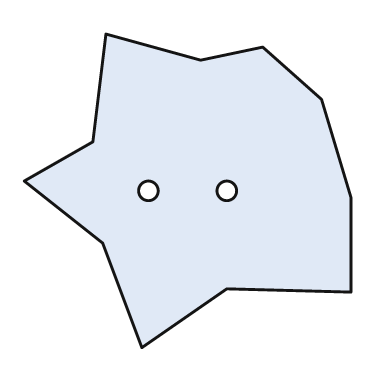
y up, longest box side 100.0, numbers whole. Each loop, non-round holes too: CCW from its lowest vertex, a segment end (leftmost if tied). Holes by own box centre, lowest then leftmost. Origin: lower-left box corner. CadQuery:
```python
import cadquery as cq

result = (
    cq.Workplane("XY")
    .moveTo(36.0, 0.0)
    .lineTo(62.0, 18.0)
    .lineTo(100.0, 17.0)
    .lineTo(100.0, 46.0)
    .lineTo(91.0, 76.0)
    .lineTo(73.0, 92.0)
    .lineTo(54.0, 88.0)
    .lineTo(25.0, 96.0)
    .lineTo(21.0, 63.0)
    .lineTo(0.0, 51.0)
    .lineTo(24.0, 32.0)
    .close()
    .moveTo(38.0, 48.0)
    .circle(3.0)
    .moveTo(62.0, 48.0)
    .circle(3.0)
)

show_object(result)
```